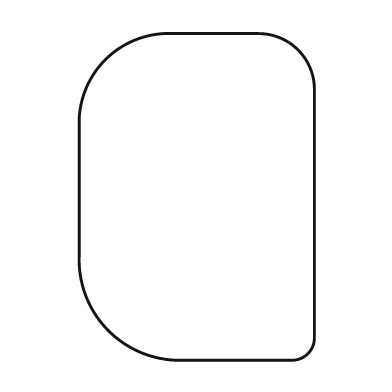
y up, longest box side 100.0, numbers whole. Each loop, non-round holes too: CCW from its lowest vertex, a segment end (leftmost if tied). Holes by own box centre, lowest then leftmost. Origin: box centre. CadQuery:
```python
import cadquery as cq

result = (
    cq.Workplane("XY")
    .moveTo(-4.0, -50.0)
    .lineTo(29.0, -50.0)
    .threePointArc((34.0, -48.0), (36.0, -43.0))
    .lineTo(36.0, 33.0)
    .threePointArc((31.0, 45.0), (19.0, 50.0))
    .lineTo(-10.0, 50.0)
    .threePointArc((-28.0, 42.0), (-36.0, 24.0))
    .lineTo(-36.0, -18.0)
    .threePointArc((-27.0, -41.0), (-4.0, -50.0))
    .close()
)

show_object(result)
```